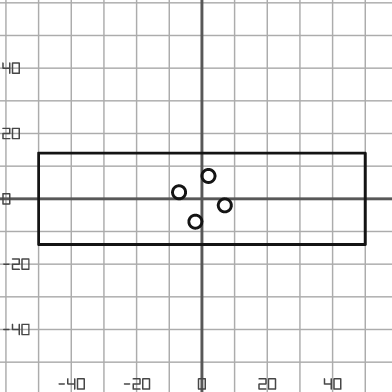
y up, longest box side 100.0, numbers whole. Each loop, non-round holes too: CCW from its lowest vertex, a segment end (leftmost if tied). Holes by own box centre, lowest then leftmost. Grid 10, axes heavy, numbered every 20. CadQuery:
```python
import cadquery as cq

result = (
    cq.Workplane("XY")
    .moveTo(-50.0, -14.0)
    .lineTo(50.0, -14.0)
    .lineTo(50.0, 14.0)
    .lineTo(-50.0, 14.0)
    .close()
    .moveTo(-2.0, -7.0)
    .circle(2.0)
    .moveTo(7.0, -2.0)
    .circle(2.0)
    .moveTo(-7.0, 2.0)
    .circle(2.0)
    .moveTo(2.0, 7.0)
    .circle(2.0)
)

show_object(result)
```